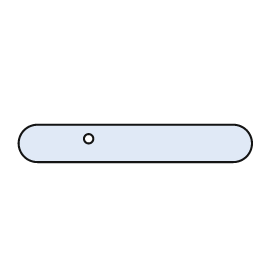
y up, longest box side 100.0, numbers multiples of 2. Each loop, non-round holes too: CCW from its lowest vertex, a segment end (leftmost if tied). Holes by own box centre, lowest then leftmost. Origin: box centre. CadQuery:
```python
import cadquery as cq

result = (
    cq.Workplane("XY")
    .moveTo(-42.0, -8.0)
    .lineTo(42.0, -8.0)
    .threePointArc((50.0, 0.0), (42.0, 8.0))
    .lineTo(-42.0, 8.0)
    .threePointArc((-50.0, 0.0), (-42.0, -8.0))
    .close()
    .moveTo(-20.0, 2.0)
    .circle(2.0)
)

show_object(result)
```